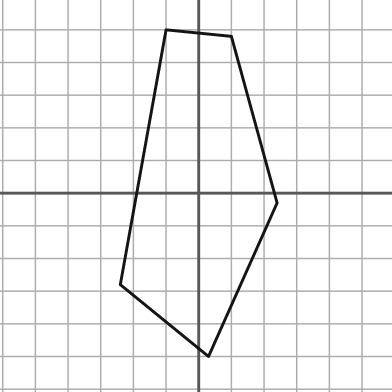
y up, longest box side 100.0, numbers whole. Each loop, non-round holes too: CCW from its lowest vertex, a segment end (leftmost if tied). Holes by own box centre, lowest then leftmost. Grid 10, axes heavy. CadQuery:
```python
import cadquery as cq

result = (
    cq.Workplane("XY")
    .moveTo(3.0, -50.0)
    .lineTo(24.0, -3.0)
    .lineTo(10.0, 48.0)
    .lineTo(-10.0, 50.0)
    .lineTo(-24.0, -28.0)
    .close()
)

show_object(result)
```